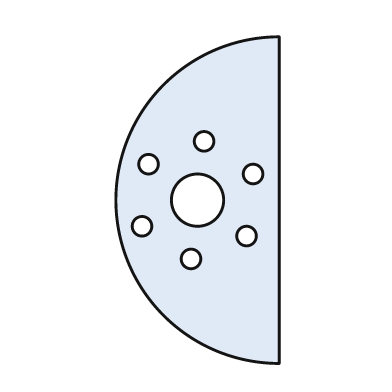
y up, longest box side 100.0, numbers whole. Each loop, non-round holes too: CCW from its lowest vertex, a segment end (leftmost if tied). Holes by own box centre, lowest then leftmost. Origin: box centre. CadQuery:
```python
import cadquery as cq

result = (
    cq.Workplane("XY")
    .moveTo(25.0, -50.0)
    .lineTo(25.0, 50.0)
    .threePointArc((-25.0, 0.0), (25.0, -50.0))
    .close()
    .moveTo(-2.0, -18.0)
    .circle(3.0)
    .moveTo(15.0, -11.0)
    .circle(3.0)
    .moveTo(-17.0, -8.0)
    .circle(3.0)
    .moveTo(0.0, 0.0)
    .circle(8.0)
    .moveTo(17.0, 8.0)
    .circle(3.0)
    .moveTo(-15.0, 11.0)
    .circle(3.0)
    .moveTo(2.0, 18.0)
    .circle(3.0)
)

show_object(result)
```